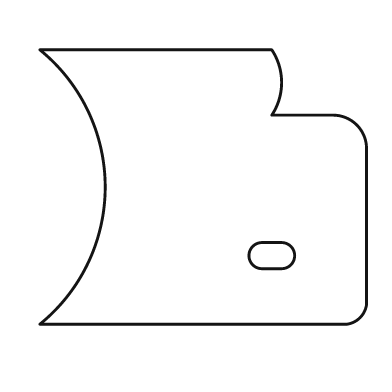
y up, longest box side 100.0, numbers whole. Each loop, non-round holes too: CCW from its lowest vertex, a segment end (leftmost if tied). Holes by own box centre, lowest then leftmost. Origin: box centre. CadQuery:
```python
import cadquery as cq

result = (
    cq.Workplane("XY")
    .moveTo(-50.0, -42.0)
    .lineTo(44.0, -42.0)
    .threePointArc((48.0, -40.0), (50.0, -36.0))
    .lineTo(50.0, 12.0)
    .threePointArc((47.0, 19.0), (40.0, 22.0))
    .lineTo(21.0, 22.0)
    .threePointArc((24.0, 32.0), (21.0, 42.0))
    .lineTo(-50.0, 42.0)
    .threePointArc((-30.0, 0.0), (-50.0, -42.0))
    .close()
    .moveTo(18.0, -25.0)
    .lineTo(24.0, -25.0)
    .threePointArc((28.0, -21.0), (24.0, -17.0))
    .lineTo(18.0, -17.0)
    .threePointArc((14.0, -21.0), (18.0, -25.0))
    .close()
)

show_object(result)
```